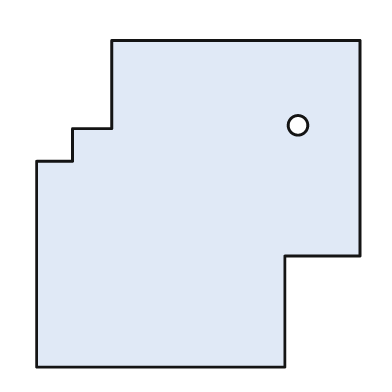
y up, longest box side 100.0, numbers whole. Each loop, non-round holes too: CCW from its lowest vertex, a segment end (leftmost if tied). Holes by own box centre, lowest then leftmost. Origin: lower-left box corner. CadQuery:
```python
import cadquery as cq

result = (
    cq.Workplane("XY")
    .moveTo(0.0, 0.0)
    .lineTo(76.0, 0.0)
    .lineTo(76.0, 34.0)
    .lineTo(99.0, 34.0)
    .lineTo(99.0, 100.0)
    .lineTo(23.0, 100.0)
    .lineTo(23.0, 73.0)
    .lineTo(11.0, 73.0)
    .lineTo(11.0, 63.0)
    .lineTo(0.0, 63.0)
    .close()
    .moveTo(80.0, 74.0)
    .circle(3.0)
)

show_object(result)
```